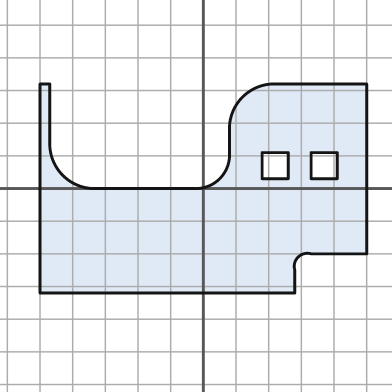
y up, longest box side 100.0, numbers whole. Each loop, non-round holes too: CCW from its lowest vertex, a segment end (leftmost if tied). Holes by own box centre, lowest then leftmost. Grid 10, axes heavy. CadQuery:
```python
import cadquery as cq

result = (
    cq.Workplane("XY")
    .moveTo(-50.0, -32.0)
    .lineTo(28.0, -32.0)
    .lineTo(28.0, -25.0)
    .threePointArc((29.0, -21.0), (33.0, -20.0))
    .lineTo(50.0, -20.0)
    .lineTo(50.0, 32.0)
    .lineTo(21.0, 32.0)
    .threePointArc((12.0, 28.0), (8.0, 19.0))
    .lineTo(8.0, 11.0)
    .threePointArc((5.0, 3.0), (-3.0, 0.0))
    .lineTo(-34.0, 0.0)
    .threePointArc((-43.0, 4.0), (-47.0, 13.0))
    .lineTo(-47.0, 32.0)
    .lineTo(-50.0, 32.0)
    .close()
    .moveTo(18.0, 3.0)
    .lineTo(26.0, 3.0)
    .lineTo(26.0, 11.0)
    .lineTo(18.0, 11.0)
    .close()
    .moveTo(33.0, 3.0)
    .lineTo(41.0, 3.0)
    .lineTo(41.0, 11.0)
    .lineTo(33.0, 11.0)
    .close()
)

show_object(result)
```